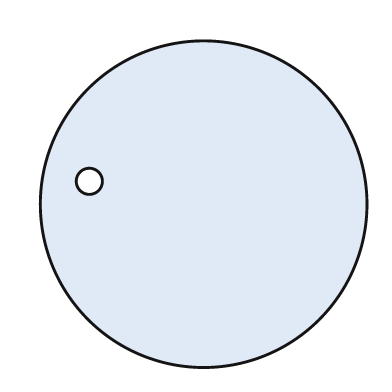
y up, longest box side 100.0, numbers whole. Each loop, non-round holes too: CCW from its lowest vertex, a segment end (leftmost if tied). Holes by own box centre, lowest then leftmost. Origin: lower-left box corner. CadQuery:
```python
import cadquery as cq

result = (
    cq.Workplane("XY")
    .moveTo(50.0, 50.0)
    .circle(50.0)
    .moveTo(15.0, 57.0)
    .circle(4.0)
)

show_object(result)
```